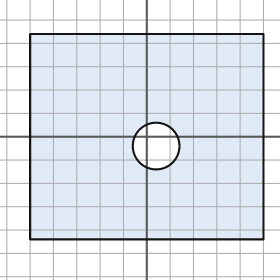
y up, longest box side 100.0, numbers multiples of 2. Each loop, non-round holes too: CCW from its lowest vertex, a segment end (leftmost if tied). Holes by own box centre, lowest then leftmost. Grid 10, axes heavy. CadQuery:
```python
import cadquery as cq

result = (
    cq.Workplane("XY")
    .moveTo(-50.0, -44.0)
    .lineTo(50.0, -44.0)
    .lineTo(50.0, 44.0)
    .lineTo(-50.0, 44.0)
    .close()
    .moveTo(4.0, -4.0)
    .circle(10.0)
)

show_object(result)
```